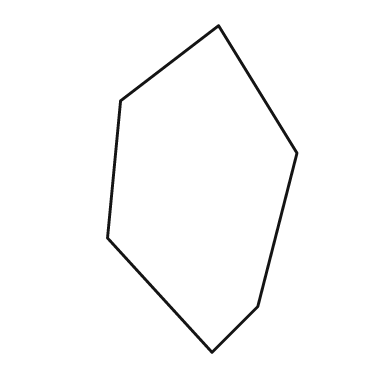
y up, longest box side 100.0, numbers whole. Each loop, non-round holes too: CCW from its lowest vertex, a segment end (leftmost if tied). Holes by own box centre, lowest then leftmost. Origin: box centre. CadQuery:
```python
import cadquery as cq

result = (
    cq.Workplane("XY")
    .moveTo(3.0, -50.0)
    .lineTo(17.0, -36.0)
    .lineTo(29.0, 11.0)
    .lineTo(5.0, 50.0)
    .lineTo(-25.0, 27.0)
    .lineTo(-29.0, -15.0)
    .close()
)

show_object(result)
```